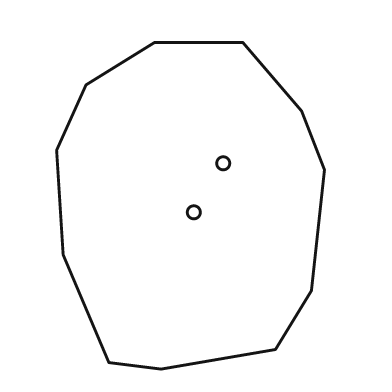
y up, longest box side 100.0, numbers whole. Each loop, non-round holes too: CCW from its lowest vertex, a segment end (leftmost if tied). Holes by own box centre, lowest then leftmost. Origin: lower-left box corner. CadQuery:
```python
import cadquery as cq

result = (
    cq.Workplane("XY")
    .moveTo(32.0, 0.0)
    .lineTo(67.0, 6.0)
    .lineTo(78.0, 24.0)
    .lineTo(82.0, 61.0)
    .lineTo(75.0, 79.0)
    .lineTo(57.0, 100.0)
    .lineTo(30.0, 100.0)
    .lineTo(9.0, 87.0)
    .lineTo(0.0, 67.0)
    .lineTo(2.0, 35.0)
    .lineTo(16.0, 2.0)
    .close()
    .moveTo(42.0, 48.0)
    .circle(2.0)
    .moveTo(51.0, 63.0)
    .circle(2.0)
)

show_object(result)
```